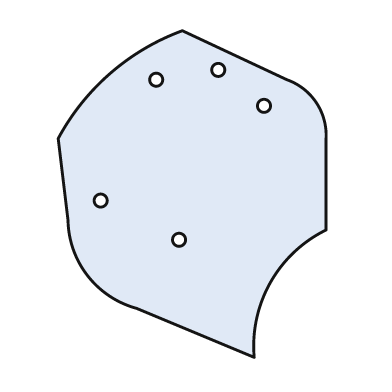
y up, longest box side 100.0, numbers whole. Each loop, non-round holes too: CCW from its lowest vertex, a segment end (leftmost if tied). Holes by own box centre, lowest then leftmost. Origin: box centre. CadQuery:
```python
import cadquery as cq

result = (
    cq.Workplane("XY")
    .moveTo(19.0, -50.0)
    .threePointArc((24.0, -27.0), (41.0, -11.0))
    .lineTo(41.0, 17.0)
    .threePointArc((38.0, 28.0), (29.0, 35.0))
    .lineTo(-3.0, 50.0)
    .threePointArc((-25.0, 37.0), (-41.0, 17.0))
    .lineTo(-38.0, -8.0)
    .threePointArc((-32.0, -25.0), (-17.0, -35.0))
    .close()
    .moveTo(-4.0, -14.0)
    .circle(2.0)
    .moveTo(-28.0, -2.0)
    .circle(2.0)
    .moveTo(22.0, 27.0)
    .circle(2.0)
    .moveTo(-11.0, 35.0)
    .circle(2.0)
    .moveTo(8.0, 38.0)
    .circle(2.0)
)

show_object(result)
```